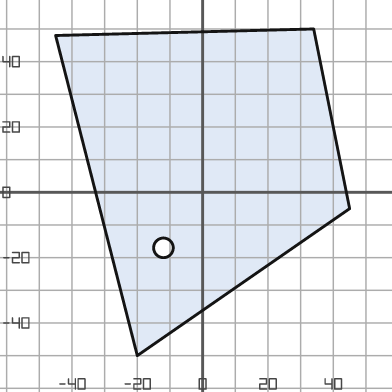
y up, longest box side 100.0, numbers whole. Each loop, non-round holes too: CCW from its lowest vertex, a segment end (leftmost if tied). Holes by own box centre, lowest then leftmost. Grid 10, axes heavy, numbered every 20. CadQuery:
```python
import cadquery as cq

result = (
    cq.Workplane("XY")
    .moveTo(-20.0, -50.0)
    .lineTo(45.0, -5.0)
    .lineTo(34.0, 50.0)
    .lineTo(-45.0, 48.0)
    .close()
    .moveTo(-12.0, -17.0)
    .circle(3.0)
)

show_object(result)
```